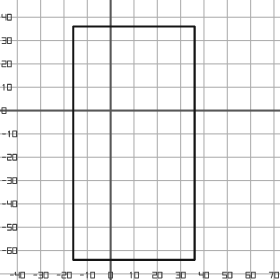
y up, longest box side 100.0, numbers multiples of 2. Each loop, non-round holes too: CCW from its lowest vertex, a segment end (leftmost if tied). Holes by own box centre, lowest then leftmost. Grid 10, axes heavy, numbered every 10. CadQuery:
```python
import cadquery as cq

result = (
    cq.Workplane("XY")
    .moveTo(-16.0, -64.0)
    .lineTo(36.0, -64.0)
    .lineTo(36.0, 36.0)
    .lineTo(-16.0, 36.0)
    .close()
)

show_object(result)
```